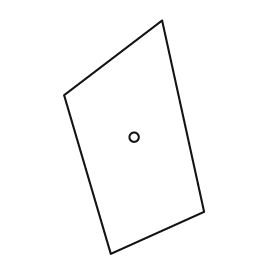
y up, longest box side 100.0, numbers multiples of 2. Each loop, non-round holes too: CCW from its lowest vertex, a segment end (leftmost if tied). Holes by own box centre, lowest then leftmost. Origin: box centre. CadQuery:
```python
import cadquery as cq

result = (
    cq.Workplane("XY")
    .moveTo(-10.0, -50.0)
    .lineTo(30.0, -32.0)
    .lineTo(12.0, 50.0)
    .lineTo(-30.0, 18.0)
    .close()
    .moveTo(0.0, 0.0)
    .circle(2.0)
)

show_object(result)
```